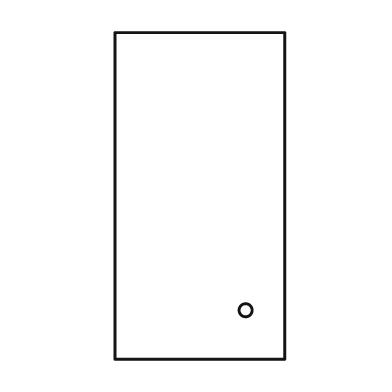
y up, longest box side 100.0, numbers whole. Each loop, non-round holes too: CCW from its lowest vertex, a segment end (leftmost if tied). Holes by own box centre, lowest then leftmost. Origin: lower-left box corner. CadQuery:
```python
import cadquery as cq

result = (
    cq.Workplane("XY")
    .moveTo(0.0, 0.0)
    .lineTo(52.0, 0.0)
    .lineTo(52.0, 100.0)
    .lineTo(0.0, 100.0)
    .close()
    .moveTo(40.0, 15.0)
    .circle(2.0)
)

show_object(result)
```